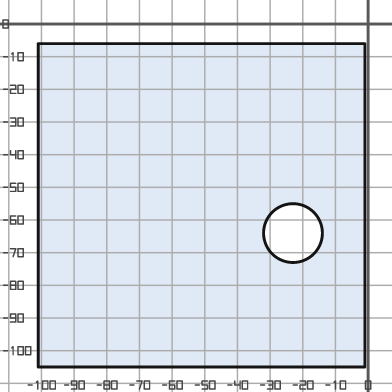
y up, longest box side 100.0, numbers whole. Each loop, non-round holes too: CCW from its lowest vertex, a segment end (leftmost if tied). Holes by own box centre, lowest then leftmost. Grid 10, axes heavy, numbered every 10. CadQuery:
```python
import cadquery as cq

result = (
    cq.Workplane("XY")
    .moveTo(-101.0, -105.0)
    .lineTo(-1.0, -105.0)
    .lineTo(-1.0, -6.0)
    .lineTo(-101.0, -6.0)
    .close()
    .moveTo(-23.0, -64.0)
    .circle(9.0)
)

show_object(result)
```